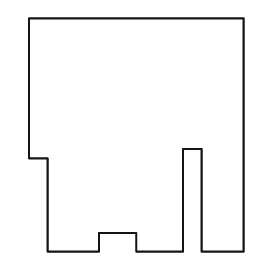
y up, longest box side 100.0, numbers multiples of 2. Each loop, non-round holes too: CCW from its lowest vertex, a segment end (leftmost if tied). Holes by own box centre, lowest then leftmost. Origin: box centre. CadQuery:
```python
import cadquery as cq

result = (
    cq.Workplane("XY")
    .moveTo(-38.0, -50.0)
    .lineTo(-16.0, -50.0)
    .lineTo(-16.0, -42.0)
    .lineTo(0.0, -42.0)
    .lineTo(0.0, -50.0)
    .lineTo(20.0, -50.0)
    .lineTo(20.0, -6.0)
    .lineTo(28.0, -6.0)
    .lineTo(28.0, -50.0)
    .lineTo(46.0, -50.0)
    .lineTo(46.0, 50.0)
    .lineTo(-46.0, 50.0)
    .lineTo(-46.0, -10.0)
    .lineTo(-38.0, -10.0)
    .close()
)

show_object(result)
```